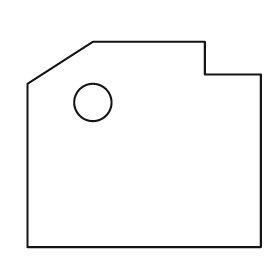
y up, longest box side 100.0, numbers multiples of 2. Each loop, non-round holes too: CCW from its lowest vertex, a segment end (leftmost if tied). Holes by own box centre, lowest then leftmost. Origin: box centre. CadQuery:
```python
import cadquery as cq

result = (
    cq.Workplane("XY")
    .moveTo(-50.0, -44.0)
    .lineTo(50.0, -44.0)
    .lineTo(50.0, 30.0)
    .lineTo(26.0, 30.0)
    .lineTo(26.0, 44.0)
    .lineTo(-22.0, 44.0)
    .lineTo(-50.0, 26.0)
    .close()
    .moveTo(-22.0, 18.0)
    .circle(8.0)
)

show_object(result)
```